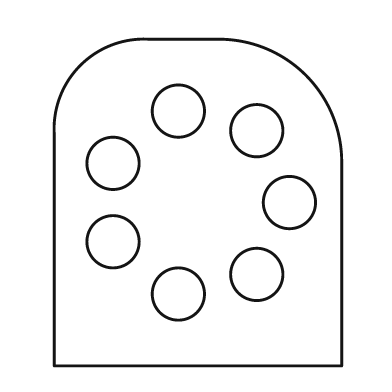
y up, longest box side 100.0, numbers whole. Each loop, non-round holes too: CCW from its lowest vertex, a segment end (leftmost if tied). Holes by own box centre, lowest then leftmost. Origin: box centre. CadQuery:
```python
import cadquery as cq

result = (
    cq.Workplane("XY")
    .moveTo(-44.0, -50.0)
    .lineTo(44.0, -50.0)
    .lineTo(44.0, 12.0)
    .threePointArc((33.0, 39.0), (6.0, 50.0))
    .lineTo(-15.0, 50.0)
    .threePointArc((-36.0, 42.0), (-44.0, 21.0))
    .close()
    .moveTo(-6.0, -28.0)
    .circle(8.0)
    .moveTo(18.0, -22.0)
    .circle(8.0)
    .moveTo(-26.0, -12.0)
    .circle(8.0)
    .moveTo(28.0, 0.0)
    .circle(8.0)
    .moveTo(-26.0, 12.0)
    .circle(8.0)
    .moveTo(18.0, 22.0)
    .circle(8.0)
    .moveTo(-6.0, 28.0)
    .circle(8.0)
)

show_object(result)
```